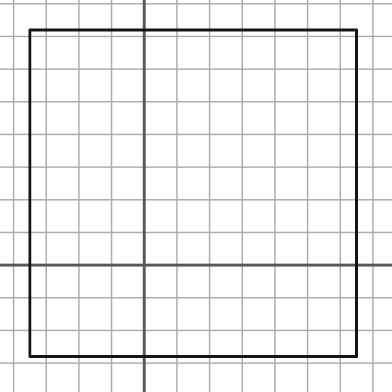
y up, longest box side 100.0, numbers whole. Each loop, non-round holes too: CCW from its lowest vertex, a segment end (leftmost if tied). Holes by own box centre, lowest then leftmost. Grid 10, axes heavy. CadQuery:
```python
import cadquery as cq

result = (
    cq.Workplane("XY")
    .moveTo(-35.0, -28.0)
    .lineTo(65.0, -28.0)
    .lineTo(65.0, 72.0)
    .lineTo(-35.0, 72.0)
    .close()
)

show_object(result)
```